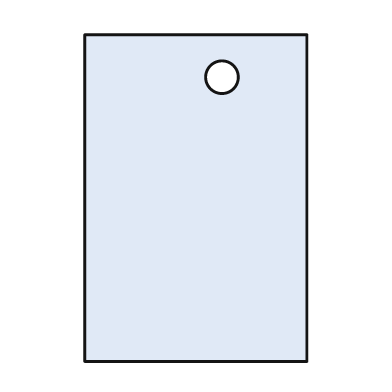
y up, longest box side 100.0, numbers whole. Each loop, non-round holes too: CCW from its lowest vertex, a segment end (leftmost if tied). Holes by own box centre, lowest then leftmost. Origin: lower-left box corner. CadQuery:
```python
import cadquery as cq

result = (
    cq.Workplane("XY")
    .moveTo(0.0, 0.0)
    .lineTo(68.0, 0.0)
    .lineTo(68.0, 100.0)
    .lineTo(0.0, 100.0)
    .close()
    .moveTo(42.0, 87.0)
    .circle(5.0)
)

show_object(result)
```